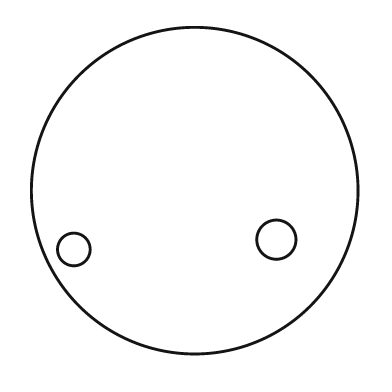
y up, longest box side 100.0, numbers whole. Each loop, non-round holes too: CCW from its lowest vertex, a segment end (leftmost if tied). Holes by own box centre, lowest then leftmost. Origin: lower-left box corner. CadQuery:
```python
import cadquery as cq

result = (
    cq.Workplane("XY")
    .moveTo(50.0, 50.0)
    .circle(50.0)
    .moveTo(13.0, 32.0)
    .circle(5.0)
    .moveTo(75.0, 35.0)
    .circle(6.0)
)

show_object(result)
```